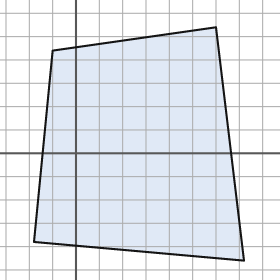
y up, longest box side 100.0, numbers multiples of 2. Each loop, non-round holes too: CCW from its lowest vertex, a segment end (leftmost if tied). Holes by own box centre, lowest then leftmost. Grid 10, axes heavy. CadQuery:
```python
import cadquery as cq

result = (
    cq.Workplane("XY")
    .moveTo(72.0, -46.0)
    .lineTo(60.0, 54.0)
    .lineTo(-10.0, 44.0)
    .lineTo(-18.0, -38.0)
    .close()
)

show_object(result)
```